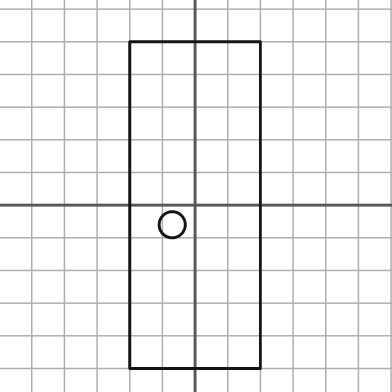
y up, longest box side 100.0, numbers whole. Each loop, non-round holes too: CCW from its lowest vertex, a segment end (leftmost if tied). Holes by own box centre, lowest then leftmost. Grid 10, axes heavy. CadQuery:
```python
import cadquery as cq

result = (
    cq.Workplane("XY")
    .moveTo(-20.0, -50.0)
    .lineTo(20.0, -50.0)
    .lineTo(20.0, 50.0)
    .lineTo(-20.0, 50.0)
    .close()
    .moveTo(-7.0, -6.0)
    .circle(4.0)
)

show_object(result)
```